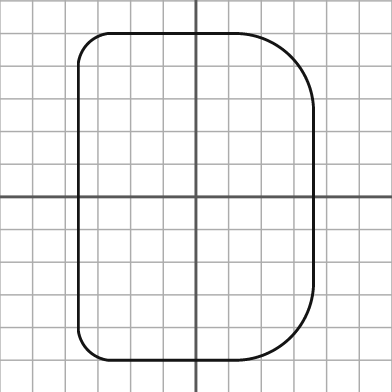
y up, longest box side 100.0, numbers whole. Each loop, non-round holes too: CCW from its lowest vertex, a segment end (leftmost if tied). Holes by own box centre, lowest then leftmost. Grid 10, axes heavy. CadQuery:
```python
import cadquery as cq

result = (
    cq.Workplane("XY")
    .moveTo(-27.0, -50.0)
    .lineTo(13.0, -50.0)
    .threePointArc((29.0, -43.0), (36.0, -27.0))
    .lineTo(36.0, 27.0)
    .threePointArc((29.0, 43.0), (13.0, 50.0))
    .lineTo(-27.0, 50.0)
    .threePointArc((-33.0, 47.0), (-36.0, 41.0))
    .lineTo(-36.0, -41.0)
    .threePointArc((-33.0, -47.0), (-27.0, -50.0))
    .close()
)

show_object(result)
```